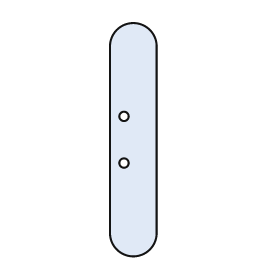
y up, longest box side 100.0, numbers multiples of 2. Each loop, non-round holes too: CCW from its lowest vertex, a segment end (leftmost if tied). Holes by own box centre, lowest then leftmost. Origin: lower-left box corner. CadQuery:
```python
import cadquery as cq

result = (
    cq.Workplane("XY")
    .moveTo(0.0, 10.0)
    .threePointArc((10.0, 0.0), (20.0, 10.0))
    .lineTo(20.0, 90.0)
    .threePointArc((10.0, 100.0), (0.0, 90.0))
    .close()
    .moveTo(6.0, 40.0)
    .circle(2.0)
    .moveTo(6.0, 60.0)
    .circle(2.0)
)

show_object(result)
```